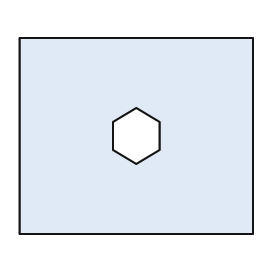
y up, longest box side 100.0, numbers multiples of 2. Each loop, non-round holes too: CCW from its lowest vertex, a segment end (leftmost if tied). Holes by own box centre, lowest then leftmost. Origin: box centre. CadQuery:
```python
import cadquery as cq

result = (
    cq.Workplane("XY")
    .moveTo(-50.0, -42.0)
    .lineTo(50.0, -42.0)
    .lineTo(50.0, 42.0)
    .lineTo(-50.0, 42.0)
    .close()
    .moveTo(0.0, -12.0)
    .lineTo(10.0, -6.0)
    .lineTo(10.0, 6.0)
    .lineTo(0.0, 12.0)
    .lineTo(-10.0, 6.0)
    .lineTo(-10.0, -6.0)
    .close()
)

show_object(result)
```